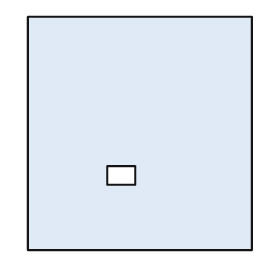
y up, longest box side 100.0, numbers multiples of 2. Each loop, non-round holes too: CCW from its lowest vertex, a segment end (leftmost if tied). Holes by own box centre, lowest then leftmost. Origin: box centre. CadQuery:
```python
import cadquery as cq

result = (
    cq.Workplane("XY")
    .moveTo(-48.0, -50.0)
    .lineTo(48.0, -50.0)
    .lineTo(48.0, 50.0)
    .lineTo(-48.0, 50.0)
    .close()
    .moveTo(-14.0, -22.0)
    .lineTo(-2.0, -22.0)
    .lineTo(-2.0, -14.0)
    .lineTo(-14.0, -14.0)
    .close()
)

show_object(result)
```